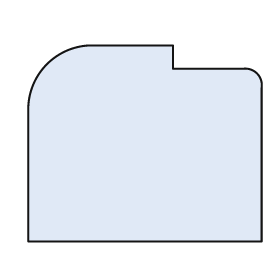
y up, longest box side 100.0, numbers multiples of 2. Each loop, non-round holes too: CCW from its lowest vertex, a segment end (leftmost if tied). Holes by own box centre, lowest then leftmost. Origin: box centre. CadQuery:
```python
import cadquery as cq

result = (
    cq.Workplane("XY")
    .moveTo(-50.0, -42.0)
    .lineTo(50.0, -42.0)
    .lineTo(50.0, 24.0)
    .threePointArc((48.0, 30.0), (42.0, 32.0))
    .lineTo(12.0, 32.0)
    .lineTo(12.0, 42.0)
    .lineTo(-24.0, 42.0)
    .threePointArc((-42.0, 34.0), (-50.0, 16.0))
    .close()
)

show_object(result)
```